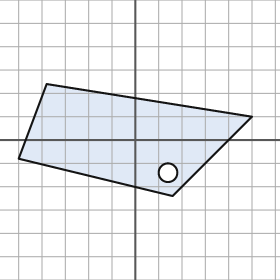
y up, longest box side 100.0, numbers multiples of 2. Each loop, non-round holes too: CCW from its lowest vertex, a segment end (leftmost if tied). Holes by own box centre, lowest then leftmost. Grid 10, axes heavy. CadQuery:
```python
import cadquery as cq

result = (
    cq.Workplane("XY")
    .moveTo(16.0, -24.0)
    .lineTo(50.0, 10.0)
    .lineTo(-38.0, 24.0)
    .lineTo(-50.0, -8.0)
    .close()
    .moveTo(14.0, -14.0)
    .circle(4.0)
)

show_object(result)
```